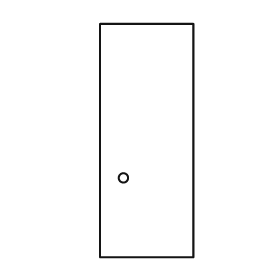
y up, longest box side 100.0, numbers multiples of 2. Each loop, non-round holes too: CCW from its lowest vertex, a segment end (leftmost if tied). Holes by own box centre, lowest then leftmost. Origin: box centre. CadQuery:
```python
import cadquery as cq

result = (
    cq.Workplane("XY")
    .moveTo(-20.0, -50.0)
    .lineTo(20.0, -50.0)
    .lineTo(20.0, 50.0)
    .lineTo(-20.0, 50.0)
    .close()
    .moveTo(-10.0, -16.0)
    .circle(2.0)
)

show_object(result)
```